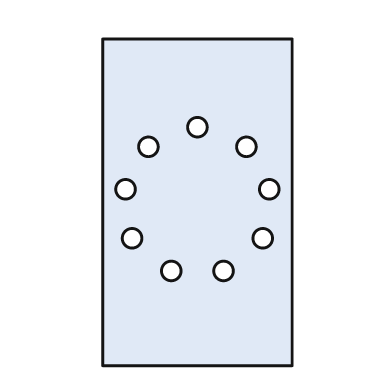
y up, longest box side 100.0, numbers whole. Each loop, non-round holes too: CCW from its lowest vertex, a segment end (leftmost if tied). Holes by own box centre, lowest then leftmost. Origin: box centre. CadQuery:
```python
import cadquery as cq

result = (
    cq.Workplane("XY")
    .moveTo(-29.0, -50.0)
    .lineTo(29.0, -50.0)
    .lineTo(29.0, 50.0)
    .lineTo(-29.0, 50.0)
    .close()
    .moveTo(-8.0, -21.0)
    .circle(3.0)
    .moveTo(8.0, -21.0)
    .circle(3.0)
    .moveTo(-20.0, -11.0)
    .circle(3.0)
    .moveTo(20.0, -11.0)
    .circle(3.0)
    .moveTo(-22.0, 4.0)
    .circle(3.0)
    .moveTo(22.0, 4.0)
    .circle(3.0)
    .moveTo(-15.0, 17.0)
    .circle(3.0)
    .moveTo(15.0, 17.0)
    .circle(3.0)
    .moveTo(0.0, 23.0)
    .circle(3.0)
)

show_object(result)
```